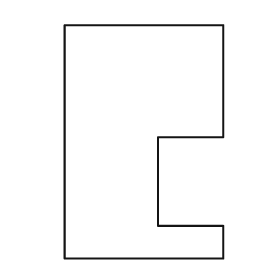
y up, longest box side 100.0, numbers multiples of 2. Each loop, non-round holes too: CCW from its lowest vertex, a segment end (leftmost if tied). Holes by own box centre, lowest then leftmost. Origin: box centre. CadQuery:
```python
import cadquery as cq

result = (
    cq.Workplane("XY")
    .moveTo(-34.0, -50.0)
    .lineTo(34.0, -50.0)
    .lineTo(34.0, -36.0)
    .lineTo(6.0, -36.0)
    .lineTo(6.0, 2.0)
    .lineTo(34.0, 2.0)
    .lineTo(34.0, 50.0)
    .lineTo(-34.0, 50.0)
    .close()
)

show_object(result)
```